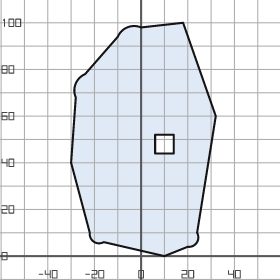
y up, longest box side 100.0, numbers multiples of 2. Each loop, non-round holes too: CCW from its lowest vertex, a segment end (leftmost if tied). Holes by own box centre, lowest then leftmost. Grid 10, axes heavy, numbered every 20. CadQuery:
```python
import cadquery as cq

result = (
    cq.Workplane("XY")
    .moveTo(10.0, 0.0)
    .lineTo(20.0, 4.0)
    .threePointArc((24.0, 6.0), (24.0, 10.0))
    .lineTo(32.0, 60.0)
    .lineTo(18.0, 100.0)
    .lineTo(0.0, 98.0)
    .threePointArc((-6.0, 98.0), (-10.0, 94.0))
    .lineTo(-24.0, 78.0)
    .threePointArc((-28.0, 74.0), (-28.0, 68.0))
    .lineTo(-30.0, 40.0)
    .lineTo(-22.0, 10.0)
    .threePointArc((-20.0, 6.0), (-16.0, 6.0))
    .close()
    .moveTo(6.0, 44.0)
    .lineTo(14.0, 44.0)
    .lineTo(14.0, 52.0)
    .lineTo(6.0, 52.0)
    .close()
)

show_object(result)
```